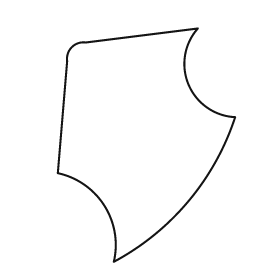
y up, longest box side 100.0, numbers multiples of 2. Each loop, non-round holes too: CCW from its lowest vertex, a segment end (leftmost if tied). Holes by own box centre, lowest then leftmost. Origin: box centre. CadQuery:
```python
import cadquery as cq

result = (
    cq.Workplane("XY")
    .moveTo(-14.0, -50.0)
    .threePointArc((18.0, -24.0), (38.0, 12.0))
    .threePointArc((18.0, 26.0), (22.0, 50.0))
    .lineTo(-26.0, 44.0)
    .threePointArc((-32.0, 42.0), (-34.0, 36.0))
    .lineTo(-38.0, -12.0)
    .threePointArc((-18.0, -26.0), (-14.0, -50.0))
    .close()
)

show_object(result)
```